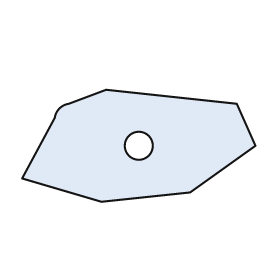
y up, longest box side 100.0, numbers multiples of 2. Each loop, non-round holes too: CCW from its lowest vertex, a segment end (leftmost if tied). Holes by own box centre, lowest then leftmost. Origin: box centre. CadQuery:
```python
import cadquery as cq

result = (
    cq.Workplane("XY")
    .moveTo(-16.0, -24.0)
    .lineTo(22.0, -20.0)
    .lineTo(50.0, 0.0)
    .lineTo(42.0, 18.0)
    .lineTo(-14.0, 24.0)
    .lineTo(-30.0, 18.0)
    .threePointArc((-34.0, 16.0), (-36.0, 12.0))
    .lineTo(-50.0, -14.0)
    .close()
    .moveTo(0.0, 0.0)
    .circle(6.0)
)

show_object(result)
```